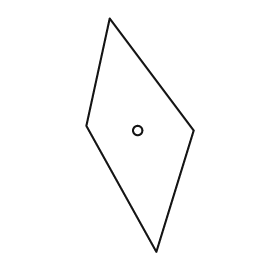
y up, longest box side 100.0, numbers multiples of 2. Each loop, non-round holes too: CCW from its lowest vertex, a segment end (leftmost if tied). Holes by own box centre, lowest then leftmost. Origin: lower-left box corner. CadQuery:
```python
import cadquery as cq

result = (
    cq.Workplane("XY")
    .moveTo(30.0, 0.0)
    .lineTo(46.0, 52.0)
    .lineTo(10.0, 100.0)
    .lineTo(0.0, 54.0)
    .close()
    .moveTo(22.0, 52.0)
    .circle(2.0)
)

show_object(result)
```